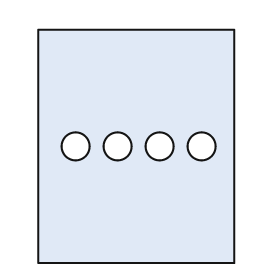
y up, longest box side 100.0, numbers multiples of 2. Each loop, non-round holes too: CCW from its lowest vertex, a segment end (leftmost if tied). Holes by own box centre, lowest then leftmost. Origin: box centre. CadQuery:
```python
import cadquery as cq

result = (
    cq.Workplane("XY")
    .moveTo(-42.0, -50.0)
    .lineTo(42.0, -50.0)
    .lineTo(42.0, 50.0)
    .lineTo(-42.0, 50.0)
    .close()
    .moveTo(-26.0, 0.0)
    .circle(6.0)
    .moveTo(-8.0, 0.0)
    .circle(6.0)
    .moveTo(10.0, 0.0)
    .circle(6.0)
    .moveTo(28.0, 0.0)
    .circle(6.0)
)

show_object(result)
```